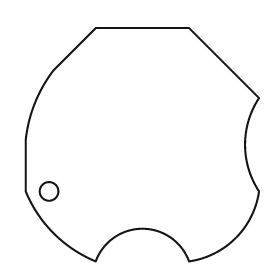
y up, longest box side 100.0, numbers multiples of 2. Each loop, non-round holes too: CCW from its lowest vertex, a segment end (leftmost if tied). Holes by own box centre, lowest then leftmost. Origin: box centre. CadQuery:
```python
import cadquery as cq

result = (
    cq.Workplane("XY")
    .moveTo(-20.0, -50.0)
    .threePointArc((0.0, -36.0), (20.0, -50.0))
    .threePointArc((40.0, -40.0), (50.0, -20.0))
    .threePointArc((44.0, 0.0), (50.0, 20.0))
    .lineTo(20.0, 50.0)
    .lineTo(-20.0, 50.0)
    .lineTo(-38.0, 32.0)
    .threePointArc((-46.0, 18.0), (-50.0, 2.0))
    .lineTo(-50.0, -20.0)
    .threePointArc((-38.0, -38.0), (-20.0, -50.0))
    .close()
    .moveTo(-40.0, -20.0)
    .circle(4.0)
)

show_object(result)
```